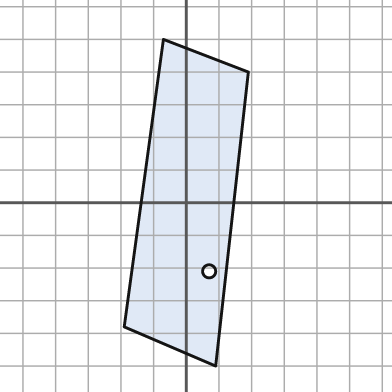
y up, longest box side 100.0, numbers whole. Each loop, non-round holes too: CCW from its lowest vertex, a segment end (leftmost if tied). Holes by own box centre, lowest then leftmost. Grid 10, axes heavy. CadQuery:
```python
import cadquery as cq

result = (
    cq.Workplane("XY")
    .moveTo(9.0, -50.0)
    .lineTo(19.0, 40.0)
    .lineTo(-7.0, 50.0)
    .lineTo(-19.0, -38.0)
    .close()
    .moveTo(7.0, -21.0)
    .circle(2.0)
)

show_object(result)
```